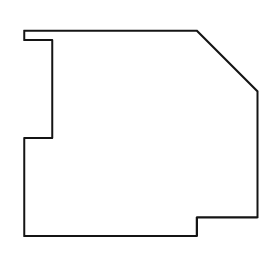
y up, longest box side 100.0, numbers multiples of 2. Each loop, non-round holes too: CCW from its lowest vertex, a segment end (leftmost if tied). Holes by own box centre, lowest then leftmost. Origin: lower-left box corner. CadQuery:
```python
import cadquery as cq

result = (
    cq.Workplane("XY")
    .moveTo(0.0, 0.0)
    .lineTo(74.0, 0.0)
    .lineTo(74.0, 8.0)
    .lineTo(100.0, 8.0)
    .lineTo(100.0, 62.0)
    .lineTo(74.0, 88.0)
    .lineTo(0.0, 88.0)
    .lineTo(0.0, 84.0)
    .lineTo(12.0, 84.0)
    .lineTo(12.0, 42.0)
    .lineTo(0.0, 42.0)
    .close()
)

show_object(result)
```